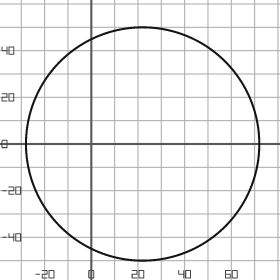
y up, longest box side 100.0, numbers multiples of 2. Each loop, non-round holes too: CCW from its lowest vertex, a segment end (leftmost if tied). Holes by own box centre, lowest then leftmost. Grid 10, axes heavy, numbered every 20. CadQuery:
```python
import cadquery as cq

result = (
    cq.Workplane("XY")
    .moveTo(22.0, 0.0)
    .circle(50.0)
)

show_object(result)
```